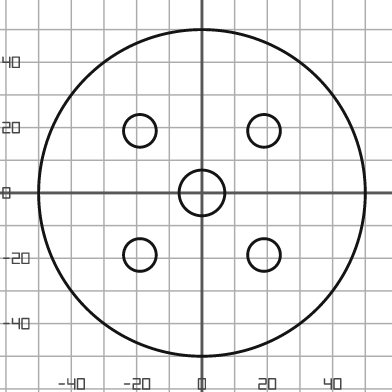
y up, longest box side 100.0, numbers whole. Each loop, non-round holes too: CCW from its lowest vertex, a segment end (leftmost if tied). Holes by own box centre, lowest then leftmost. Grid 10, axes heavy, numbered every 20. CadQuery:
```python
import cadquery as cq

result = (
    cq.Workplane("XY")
    .moveTo(0.0, 0.0)
    .circle(50.0)
    .moveTo(-19.0, -19.0)
    .circle(5.0)
    .moveTo(19.0, -19.0)
    .circle(5.0)
    .moveTo(0.0, 0.0)
    .circle(7.0)
    .moveTo(-19.0, 19.0)
    .circle(5.0)
    .moveTo(19.0, 19.0)
    .circle(5.0)
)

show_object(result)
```